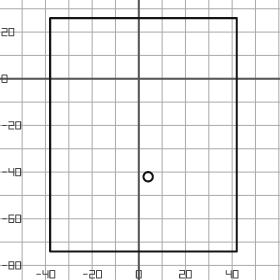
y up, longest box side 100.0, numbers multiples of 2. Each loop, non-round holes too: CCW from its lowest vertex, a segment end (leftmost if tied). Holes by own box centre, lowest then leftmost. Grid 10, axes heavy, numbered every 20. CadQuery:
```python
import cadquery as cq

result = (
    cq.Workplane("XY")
    .moveTo(-38.0, -74.0)
    .lineTo(42.0, -74.0)
    .lineTo(42.0, 26.0)
    .lineTo(-38.0, 26.0)
    .close()
    .moveTo(4.0, -42.0)
    .circle(2.0)
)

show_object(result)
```